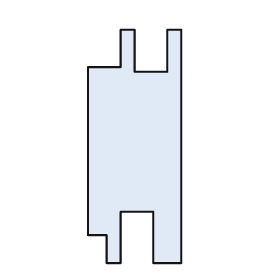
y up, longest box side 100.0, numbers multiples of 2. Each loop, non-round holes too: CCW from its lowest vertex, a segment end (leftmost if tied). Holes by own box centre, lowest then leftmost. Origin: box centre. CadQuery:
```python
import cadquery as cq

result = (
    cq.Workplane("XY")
    .moveTo(-12.0, -50.0)
    .lineTo(-6.0, -50.0)
    .lineTo(-6.0, -28.0)
    .lineTo(8.0, -28.0)
    .lineTo(8.0, -50.0)
    .lineTo(20.0, -50.0)
    .lineTo(20.0, 50.0)
    .lineTo(14.0, 50.0)
    .lineTo(14.0, 32.0)
    .lineTo(0.0, 32.0)
    .lineTo(0.0, 50.0)
    .lineTo(-6.0, 50.0)
    .lineTo(-6.0, 34.0)
    .lineTo(-20.0, 34.0)
    .lineTo(-20.0, -38.0)
    .lineTo(-12.0, -38.0)
    .close()
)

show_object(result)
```